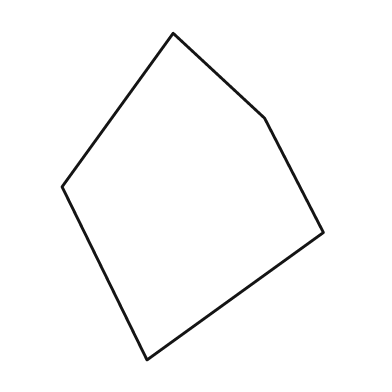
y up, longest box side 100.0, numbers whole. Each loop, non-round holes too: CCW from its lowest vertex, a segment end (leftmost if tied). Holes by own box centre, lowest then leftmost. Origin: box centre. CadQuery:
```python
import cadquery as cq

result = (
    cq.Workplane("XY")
    .moveTo(-14.0, -50.0)
    .lineTo(40.0, -11.0)
    .lineTo(22.0, 24.0)
    .lineTo(-6.0, 50.0)
    .lineTo(-40.0, 3.0)
    .close()
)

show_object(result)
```